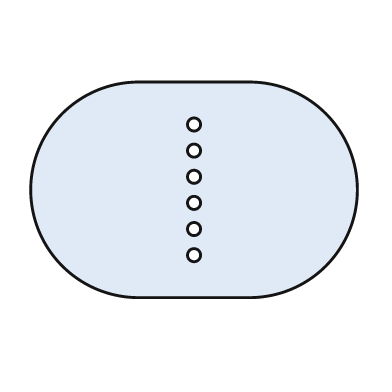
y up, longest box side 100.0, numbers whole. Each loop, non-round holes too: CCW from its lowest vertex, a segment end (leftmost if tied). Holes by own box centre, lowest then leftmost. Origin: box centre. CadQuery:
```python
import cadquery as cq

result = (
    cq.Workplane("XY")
    .moveTo(-17.0, -33.0)
    .lineTo(17.0, -33.0)
    .threePointArc((50.0, 0.0), (17.0, 33.0))
    .lineTo(-17.0, 33.0)
    .threePointArc((-50.0, 0.0), (-17.0, -33.0))
    .close()
    .moveTo(0.0, -20.0)
    .circle(2.0)
    .moveTo(0.0, -12.0)
    .circle(2.0)
    .moveTo(0.0, -4.0)
    .circle(2.0)
    .moveTo(0.0, 4.0)
    .circle(2.0)
    .moveTo(0.0, 12.0)
    .circle(2.0)
    .moveTo(0.0, 20.0)
    .circle(2.0)
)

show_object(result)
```